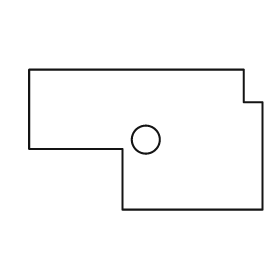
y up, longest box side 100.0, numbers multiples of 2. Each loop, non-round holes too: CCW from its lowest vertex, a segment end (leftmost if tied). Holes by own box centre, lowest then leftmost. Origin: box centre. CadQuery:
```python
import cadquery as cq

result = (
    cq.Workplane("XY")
    .moveTo(-10.0, -30.0)
    .lineTo(50.0, -30.0)
    .lineTo(50.0, 16.0)
    .lineTo(42.0, 16.0)
    .lineTo(42.0, 30.0)
    .lineTo(-50.0, 30.0)
    .lineTo(-50.0, -4.0)
    .lineTo(-10.0, -4.0)
    .close()
    .moveTo(0.0, 0.0)
    .circle(6.0)
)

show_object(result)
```